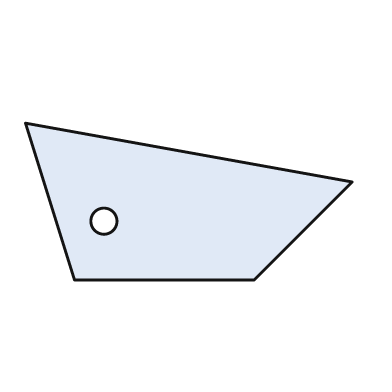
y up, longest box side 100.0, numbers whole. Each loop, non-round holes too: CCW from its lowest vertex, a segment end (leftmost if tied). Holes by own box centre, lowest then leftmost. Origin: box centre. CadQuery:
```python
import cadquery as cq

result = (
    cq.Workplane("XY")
    .moveTo(-35.0, -24.0)
    .lineTo(20.0, -24.0)
    .lineTo(50.0, 6.0)
    .lineTo(-50.0, 24.0)
    .close()
    .moveTo(-26.0, -6.0)
    .circle(4.0)
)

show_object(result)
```